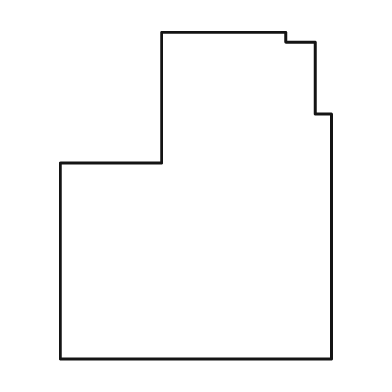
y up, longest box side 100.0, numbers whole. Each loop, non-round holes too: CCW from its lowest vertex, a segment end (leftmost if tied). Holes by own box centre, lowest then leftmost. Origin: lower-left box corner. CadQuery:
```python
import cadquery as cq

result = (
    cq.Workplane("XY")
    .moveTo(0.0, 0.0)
    .lineTo(83.0, 0.0)
    .lineTo(83.0, 75.0)
    .lineTo(78.0, 75.0)
    .lineTo(78.0, 97.0)
    .lineTo(69.0, 97.0)
    .lineTo(69.0, 100.0)
    .lineTo(31.0, 100.0)
    .lineTo(31.0, 60.0)
    .lineTo(0.0, 60.0)
    .close()
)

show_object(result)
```